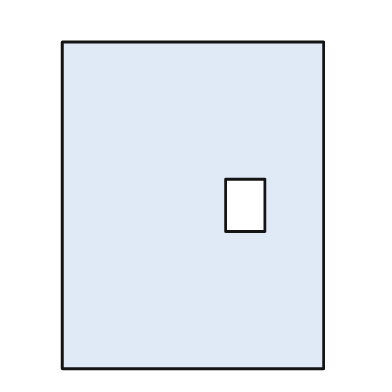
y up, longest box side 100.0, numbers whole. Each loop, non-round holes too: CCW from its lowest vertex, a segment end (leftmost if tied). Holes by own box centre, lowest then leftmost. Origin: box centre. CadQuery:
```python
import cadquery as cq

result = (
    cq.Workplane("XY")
    .moveTo(-40.0, -50.0)
    .lineTo(40.0, -50.0)
    .lineTo(40.0, 50.0)
    .lineTo(-40.0, 50.0)
    .close()
    .moveTo(10.0, -8.0)
    .lineTo(22.0, -8.0)
    .lineTo(22.0, 8.0)
    .lineTo(10.0, 8.0)
    .close()
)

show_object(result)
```